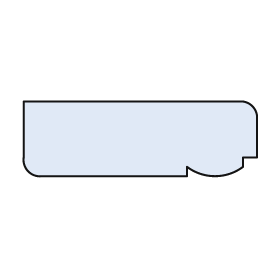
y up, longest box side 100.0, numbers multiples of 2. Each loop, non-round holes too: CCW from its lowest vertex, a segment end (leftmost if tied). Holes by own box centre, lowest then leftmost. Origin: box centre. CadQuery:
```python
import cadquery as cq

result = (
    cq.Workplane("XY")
    .moveTo(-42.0, -16.0)
    .lineTo(20.0, -16.0)
    .lineTo(20.0, -12.0)
    .threePointArc((32.0, -16.0), (44.0, -12.0))
    .lineTo(44.0, -8.0)
    .lineTo(50.0, -8.0)
    .lineTo(50.0, 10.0)
    .threePointArc((48.0, 14.0), (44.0, 16.0))
    .lineTo(-50.0, 16.0)
    .lineTo(-50.0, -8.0)
    .threePointArc((-48.0, -14.0), (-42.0, -16.0))
    .close()
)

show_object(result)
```